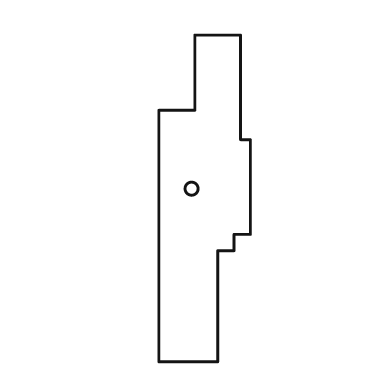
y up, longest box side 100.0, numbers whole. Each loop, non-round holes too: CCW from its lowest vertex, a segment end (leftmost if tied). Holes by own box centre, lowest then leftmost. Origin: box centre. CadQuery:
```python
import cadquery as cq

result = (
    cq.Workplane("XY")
    .moveTo(-14.0, -50.0)
    .lineTo(4.0, -50.0)
    .lineTo(4.0, -16.0)
    .lineTo(9.0, -16.0)
    .lineTo(9.0, -11.0)
    .lineTo(14.0, -11.0)
    .lineTo(14.0, 18.0)
    .lineTo(11.0, 18.0)
    .lineTo(11.0, 50.0)
    .lineTo(-3.0, 50.0)
    .lineTo(-3.0, 27.0)
    .lineTo(-14.0, 27.0)
    .close()
    .moveTo(-4.0, 3.0)
    .circle(2.0)
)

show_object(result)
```